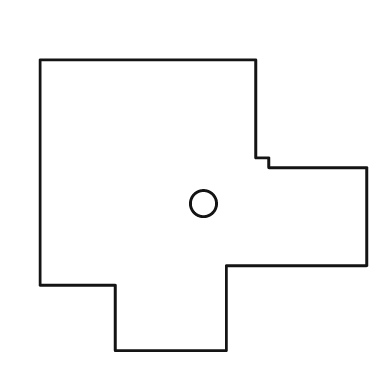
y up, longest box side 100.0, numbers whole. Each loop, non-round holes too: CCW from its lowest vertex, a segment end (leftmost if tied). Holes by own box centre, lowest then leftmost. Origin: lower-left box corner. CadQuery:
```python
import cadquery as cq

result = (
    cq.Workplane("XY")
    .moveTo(23.0, 0.0)
    .lineTo(57.0, 0.0)
    .lineTo(57.0, 26.0)
    .lineTo(100.0, 26.0)
    .lineTo(100.0, 56.0)
    .lineTo(70.0, 56.0)
    .lineTo(70.0, 59.0)
    .lineTo(66.0, 59.0)
    .lineTo(66.0, 89.0)
    .lineTo(0.0, 89.0)
    .lineTo(0.0, 20.0)
    .lineTo(23.0, 20.0)
    .close()
    .moveTo(50.0, 45.0)
    .circle(4.0)
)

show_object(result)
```